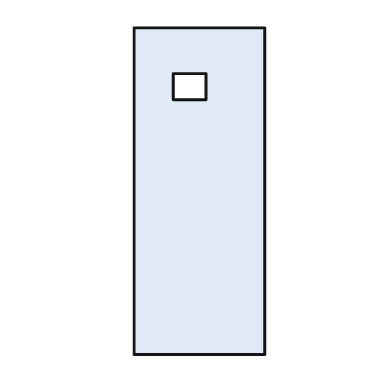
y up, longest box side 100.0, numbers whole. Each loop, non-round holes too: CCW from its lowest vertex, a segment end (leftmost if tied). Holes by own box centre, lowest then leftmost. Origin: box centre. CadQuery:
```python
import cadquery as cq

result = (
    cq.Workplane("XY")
    .moveTo(-20.0, -50.0)
    .lineTo(20.0, -50.0)
    .lineTo(20.0, 50.0)
    .lineTo(-20.0, 50.0)
    .close()
    .moveTo(-8.0, 28.0)
    .lineTo(2.0, 28.0)
    .lineTo(2.0, 36.0)
    .lineTo(-8.0, 36.0)
    .close()
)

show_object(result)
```